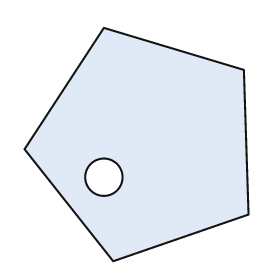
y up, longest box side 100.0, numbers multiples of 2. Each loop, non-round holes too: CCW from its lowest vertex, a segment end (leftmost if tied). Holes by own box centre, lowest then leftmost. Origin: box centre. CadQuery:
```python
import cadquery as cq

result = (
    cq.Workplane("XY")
    .moveTo(-10.0, -50.0)
    .lineTo(48.0, -30.0)
    .lineTo(46.0, 32.0)
    .lineTo(-14.0, 50.0)
    .lineTo(-48.0, -2.0)
    .close()
    .moveTo(-14.0, -14.0)
    .circle(8.0)
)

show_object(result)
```